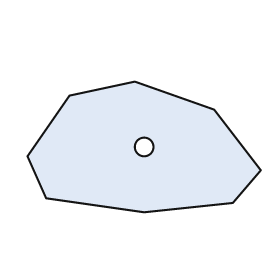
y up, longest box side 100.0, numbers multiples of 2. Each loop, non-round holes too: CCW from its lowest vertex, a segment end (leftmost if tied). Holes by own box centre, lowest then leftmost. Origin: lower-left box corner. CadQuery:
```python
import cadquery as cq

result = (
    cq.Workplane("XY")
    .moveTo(50.0, 0.0)
    .lineTo(88.0, 4.0)
    .lineTo(100.0, 18.0)
    .lineTo(80.0, 44.0)
    .lineTo(46.0, 56.0)
    .lineTo(18.0, 50.0)
    .lineTo(0.0, 24.0)
    .lineTo(8.0, 6.0)
    .close()
    .moveTo(50.0, 28.0)
    .circle(4.0)
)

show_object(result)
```